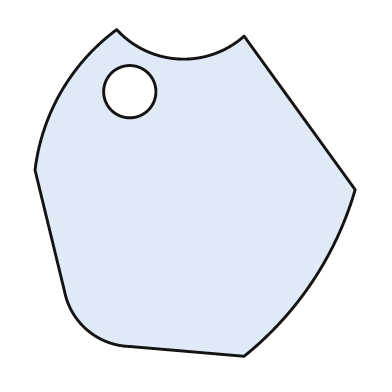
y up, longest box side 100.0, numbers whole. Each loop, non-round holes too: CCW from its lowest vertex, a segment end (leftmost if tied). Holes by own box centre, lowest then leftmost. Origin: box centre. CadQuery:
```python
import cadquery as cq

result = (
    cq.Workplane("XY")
    .moveTo(15.0, -50.0)
    .threePointArc((36.0, -27.0), (49.0, 1.0))
    .lineTo(15.0, 48.0)
    .threePointArc((-5.0, 41.0), (-24.0, 50.0))
    .threePointArc((-41.0, 31.0), (-49.0, 7.0))
    .lineTo(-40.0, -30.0)
    .threePointArc((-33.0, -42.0), (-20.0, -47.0))
    .close()
    .moveTo(-20.0, 31.0)
    .circle(8.0)
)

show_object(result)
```